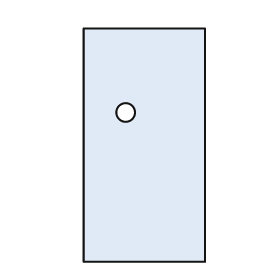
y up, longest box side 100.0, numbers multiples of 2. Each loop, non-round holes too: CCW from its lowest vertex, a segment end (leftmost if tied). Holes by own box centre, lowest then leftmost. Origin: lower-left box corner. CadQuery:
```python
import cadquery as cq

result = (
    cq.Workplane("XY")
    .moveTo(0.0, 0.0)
    .lineTo(52.0, 0.0)
    .lineTo(52.0, 100.0)
    .lineTo(0.0, 100.0)
    .close()
    .moveTo(18.0, 64.0)
    .circle(4.0)
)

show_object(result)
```